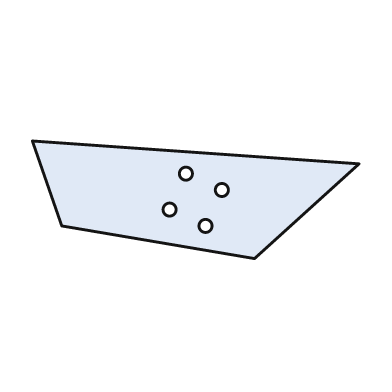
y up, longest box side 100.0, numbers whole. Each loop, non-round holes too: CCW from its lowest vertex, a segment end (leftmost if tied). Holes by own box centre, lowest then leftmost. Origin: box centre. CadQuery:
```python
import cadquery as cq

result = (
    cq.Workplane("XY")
    .moveTo(18.0, -18.0)
    .lineTo(50.0, 11.0)
    .lineTo(-50.0, 18.0)
    .lineTo(-41.0, -8.0)
    .close()
    .moveTo(3.0, -8.0)
    .circle(2.0)
    .moveTo(-8.0, -3.0)
    .circle(2.0)
    .moveTo(8.0, 3.0)
    .circle(2.0)
    .moveTo(-3.0, 8.0)
    .circle(2.0)
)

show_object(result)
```